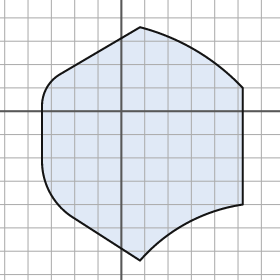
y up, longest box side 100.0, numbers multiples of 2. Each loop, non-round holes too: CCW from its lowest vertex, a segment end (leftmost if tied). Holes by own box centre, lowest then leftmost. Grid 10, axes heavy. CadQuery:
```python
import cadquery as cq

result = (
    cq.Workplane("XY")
    .moveTo(8.0, -64.0)
    .threePointArc((28.0, -48.0), (52.0, -40.0))
    .lineTo(52.0, 10.0)
    .threePointArc((32.0, 26.0), (8.0, 36.0))
    .lineTo(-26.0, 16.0)
    .threePointArc((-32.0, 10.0), (-34.0, 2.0))
    .lineTo(-34.0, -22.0)
    .threePointArc((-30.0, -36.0), (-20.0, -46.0))
    .close()
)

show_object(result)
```